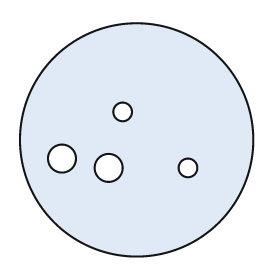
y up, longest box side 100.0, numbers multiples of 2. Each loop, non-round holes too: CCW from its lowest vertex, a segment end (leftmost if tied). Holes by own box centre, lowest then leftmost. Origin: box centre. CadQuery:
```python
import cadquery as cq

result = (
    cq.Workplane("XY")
    .moveTo(0.0, 0.0)
    .circle(50.0)
    .moveTo(-12.0, -12.0)
    .circle(6.0)
    .moveTo(22.0, -12.0)
    .circle(4.0)
    .moveTo(-32.0, -8.0)
    .circle(6.0)
    .moveTo(-6.0, 12.0)
    .circle(4.0)
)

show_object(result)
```